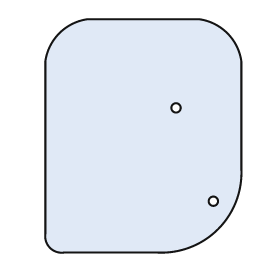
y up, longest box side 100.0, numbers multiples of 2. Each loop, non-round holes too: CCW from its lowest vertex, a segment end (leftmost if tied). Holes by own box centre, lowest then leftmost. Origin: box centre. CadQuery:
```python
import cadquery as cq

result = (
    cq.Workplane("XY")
    .moveTo(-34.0, -50.0)
    .lineTo(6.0, -50.0)
    .threePointArc((32.0, -40.0), (42.0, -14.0))
    .lineTo(42.0, 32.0)
    .threePointArc((36.0, 44.0), (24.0, 50.0))
    .lineTo(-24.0, 50.0)
    .threePointArc((-36.0, 44.0), (-42.0, 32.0))
    .lineTo(-42.0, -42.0)
    .threePointArc((-40.0, -48.0), (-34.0, -50.0))
    .close()
    .moveTo(30.0, -28.0)
    .circle(2.0)
    .moveTo(14.0, 12.0)
    .circle(2.0)
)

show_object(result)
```